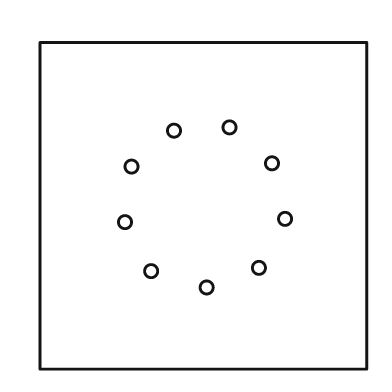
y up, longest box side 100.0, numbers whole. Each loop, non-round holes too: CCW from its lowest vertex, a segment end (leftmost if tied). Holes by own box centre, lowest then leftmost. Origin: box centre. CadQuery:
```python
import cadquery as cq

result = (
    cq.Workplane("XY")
    .moveTo(-50.0, -50.0)
    .lineTo(50.0, -50.0)
    .lineTo(50.0, 50.0)
    .lineTo(-50.0, 50.0)
    .close()
    .moveTo(1.0, -25.0)
    .circle(2.0)
    .moveTo(-16.0, -20.0)
    .circle(2.0)
    .moveTo(17.0, -19.0)
    .circle(2.0)
    .moveTo(-24.0, -5.0)
    .circle(2.0)
    .moveTo(25.0, -4.0)
    .circle(2.0)
    .moveTo(-22.0, 12.0)
    .circle(2.0)
    .moveTo(21.0, 13.0)
    .circle(2.0)
    .moveTo(-9.0, 23.0)
    .circle(2.0)
    .moveTo(8.0, 24.0)
    .circle(2.0)
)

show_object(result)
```